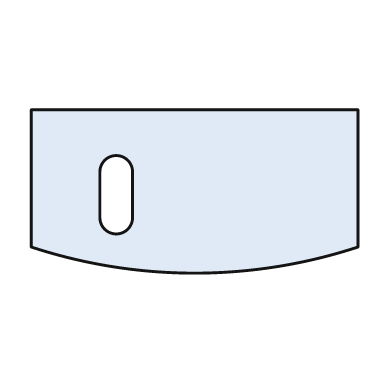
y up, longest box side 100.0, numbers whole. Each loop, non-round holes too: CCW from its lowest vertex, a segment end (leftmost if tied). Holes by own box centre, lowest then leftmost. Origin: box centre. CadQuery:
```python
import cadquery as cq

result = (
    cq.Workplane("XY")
    .moveTo(-50.0, -17.0)
    .threePointArc((0.0, -25.0), (50.0, -17.0))
    .lineTo(50.0, 25.0)
    .lineTo(-50.0, 25.0)
    .close()
    .moveTo(-29.0, -8.0)
    .threePointArc((-24.0, -13.0), (-19.0, -8.0))
    .lineTo(-19.0, 6.0)
    .threePointArc((-24.0, 11.0), (-29.0, 6.0))
    .close()
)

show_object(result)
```